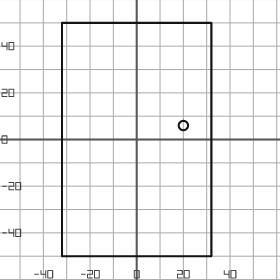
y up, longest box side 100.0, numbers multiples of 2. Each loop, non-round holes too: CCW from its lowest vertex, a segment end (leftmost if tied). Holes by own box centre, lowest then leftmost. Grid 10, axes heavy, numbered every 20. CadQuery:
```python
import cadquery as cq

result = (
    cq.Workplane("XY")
    .moveTo(-32.0, -50.0)
    .lineTo(32.0, -50.0)
    .lineTo(32.0, 50.0)
    .lineTo(-32.0, 50.0)
    .close()
    .moveTo(20.0, 6.0)
    .circle(2.0)
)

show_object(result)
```